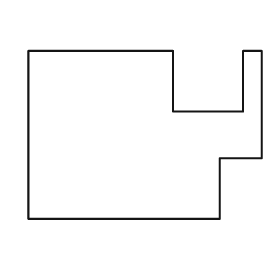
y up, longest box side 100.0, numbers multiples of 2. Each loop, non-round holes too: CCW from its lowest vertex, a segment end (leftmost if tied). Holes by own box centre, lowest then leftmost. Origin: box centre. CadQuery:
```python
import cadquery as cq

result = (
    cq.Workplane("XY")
    .moveTo(-50.0, -36.0)
    .lineTo(32.0, -36.0)
    .lineTo(32.0, -10.0)
    .lineTo(50.0, -10.0)
    .lineTo(50.0, 36.0)
    .lineTo(42.0, 36.0)
    .lineTo(42.0, 10.0)
    .lineTo(12.0, 10.0)
    .lineTo(12.0, 36.0)
    .lineTo(-50.0, 36.0)
    .close()
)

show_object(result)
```